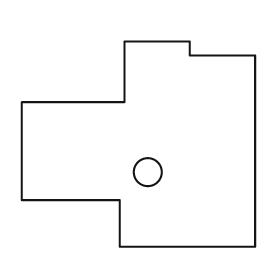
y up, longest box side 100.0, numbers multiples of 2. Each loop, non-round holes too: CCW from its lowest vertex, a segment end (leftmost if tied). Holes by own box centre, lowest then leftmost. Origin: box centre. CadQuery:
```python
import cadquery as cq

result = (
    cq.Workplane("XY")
    .moveTo(-8.0, -44.0)
    .lineTo(50.0, -44.0)
    .lineTo(50.0, 38.0)
    .lineTo(22.0, 38.0)
    .lineTo(22.0, 44.0)
    .lineTo(-6.0, 44.0)
    .lineTo(-6.0, 18.0)
    .lineTo(-50.0, 18.0)
    .lineTo(-50.0, -24.0)
    .lineTo(-8.0, -24.0)
    .close()
    .moveTo(4.0, -12.0)
    .circle(6.0)
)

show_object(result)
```